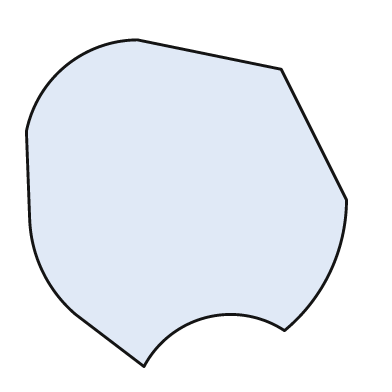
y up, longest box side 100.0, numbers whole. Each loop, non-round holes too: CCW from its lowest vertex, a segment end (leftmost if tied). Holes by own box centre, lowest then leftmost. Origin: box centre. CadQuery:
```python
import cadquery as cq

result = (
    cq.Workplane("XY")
    .moveTo(-13.0, -50.0)
    .threePointArc((6.0, -35.0), (30.0, -39.0))
    .threePointArc((44.0, -21.0), (49.0, 1.0))
    .lineTo(29.0, 41.0)
    .lineTo(-15.0, 50.0)
    .threePointArc((-37.0, 42.0), (-49.0, 22.0))
    .lineTo(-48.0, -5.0)
    .threePointArc((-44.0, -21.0), (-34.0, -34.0))
    .close()
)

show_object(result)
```